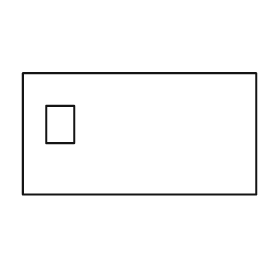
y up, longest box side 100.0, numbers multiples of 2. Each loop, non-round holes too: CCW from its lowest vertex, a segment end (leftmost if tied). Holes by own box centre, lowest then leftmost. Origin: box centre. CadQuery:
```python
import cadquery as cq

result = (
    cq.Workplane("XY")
    .moveTo(-50.0, -26.0)
    .lineTo(50.0, -26.0)
    .lineTo(50.0, 26.0)
    .lineTo(-50.0, 26.0)
    .close()
    .moveTo(-40.0, -4.0)
    .lineTo(-28.0, -4.0)
    .lineTo(-28.0, 12.0)
    .lineTo(-40.0, 12.0)
    .close()
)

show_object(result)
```